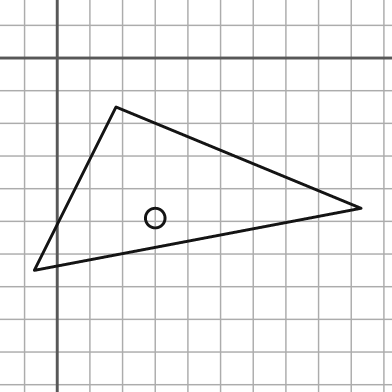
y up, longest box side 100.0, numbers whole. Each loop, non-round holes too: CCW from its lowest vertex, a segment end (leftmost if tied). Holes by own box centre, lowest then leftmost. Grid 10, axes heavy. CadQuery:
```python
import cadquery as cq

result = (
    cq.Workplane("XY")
    .moveTo(-7.0, -65.0)
    .lineTo(93.0, -46.0)
    .lineTo(18.0, -15.0)
    .close()
    .moveTo(30.0, -49.0)
    .circle(3.0)
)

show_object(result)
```